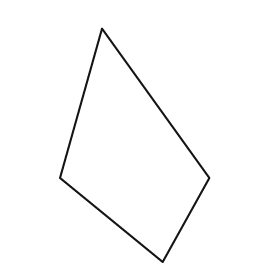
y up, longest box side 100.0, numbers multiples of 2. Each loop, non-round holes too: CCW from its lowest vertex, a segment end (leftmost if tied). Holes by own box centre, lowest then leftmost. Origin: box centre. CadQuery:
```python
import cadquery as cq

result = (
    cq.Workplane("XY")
    .moveTo(12.0, -50.0)
    .lineTo(32.0, -14.0)
    .lineTo(-14.0, 50.0)
    .lineTo(-32.0, -14.0)
    .close()
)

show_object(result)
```